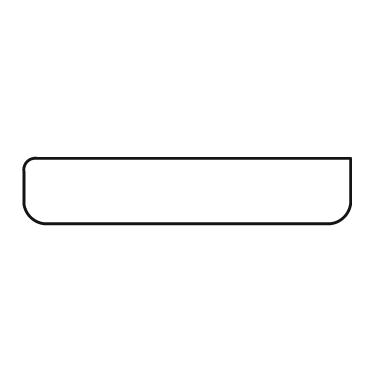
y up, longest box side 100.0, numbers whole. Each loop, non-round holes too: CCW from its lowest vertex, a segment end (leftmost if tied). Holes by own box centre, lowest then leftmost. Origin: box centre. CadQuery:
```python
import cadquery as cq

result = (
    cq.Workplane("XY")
    .moveTo(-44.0, -10.0)
    .lineTo(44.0, -10.0)
    .threePointArc((48.0, -8.0), (50.0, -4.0))
    .lineTo(50.0, 10.0)
    .lineTo(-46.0, 10.0)
    .threePointArc((-49.0, 9.0), (-50.0, 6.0))
    .lineTo(-50.0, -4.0)
    .threePointArc((-48.0, -8.0), (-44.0, -10.0))
    .close()
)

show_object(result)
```